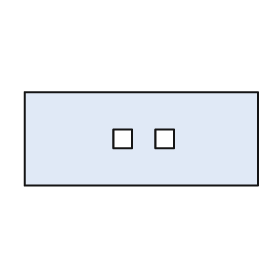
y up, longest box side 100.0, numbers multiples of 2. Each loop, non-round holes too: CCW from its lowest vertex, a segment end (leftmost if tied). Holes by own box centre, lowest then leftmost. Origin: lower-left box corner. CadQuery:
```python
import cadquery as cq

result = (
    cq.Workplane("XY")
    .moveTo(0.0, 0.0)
    .lineTo(100.0, 0.0)
    .lineTo(100.0, 40.0)
    .lineTo(0.0, 40.0)
    .close()
    .moveTo(38.0, 16.0)
    .lineTo(46.0, 16.0)
    .lineTo(46.0, 24.0)
    .lineTo(38.0, 24.0)
    .close()
    .moveTo(56.0, 16.0)
    .lineTo(64.0, 16.0)
    .lineTo(64.0, 24.0)
    .lineTo(56.0, 24.0)
    .close()
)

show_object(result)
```